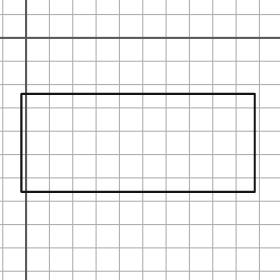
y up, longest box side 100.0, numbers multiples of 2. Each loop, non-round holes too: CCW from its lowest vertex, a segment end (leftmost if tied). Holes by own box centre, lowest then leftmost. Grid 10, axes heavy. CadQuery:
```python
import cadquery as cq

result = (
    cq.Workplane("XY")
    .moveTo(-2.0, -66.0)
    .lineTo(98.0, -66.0)
    .lineTo(98.0, -24.0)
    .lineTo(-2.0, -24.0)
    .close()
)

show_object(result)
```